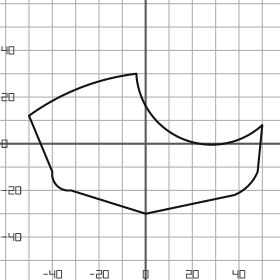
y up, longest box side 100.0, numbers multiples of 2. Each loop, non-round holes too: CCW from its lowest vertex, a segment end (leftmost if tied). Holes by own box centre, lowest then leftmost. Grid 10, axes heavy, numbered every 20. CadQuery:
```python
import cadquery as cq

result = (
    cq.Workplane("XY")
    .moveTo(0.0, -30.0)
    .lineTo(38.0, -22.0)
    .threePointArc((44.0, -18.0), (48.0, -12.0))
    .lineTo(50.0, 8.0)
    .threePointArc((16.0, 2.0), (-4.0, 30.0))
    .threePointArc((-28.0, 24.0), (-50.0, 12.0))
    .lineTo(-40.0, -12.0)
    .threePointArc((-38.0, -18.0), (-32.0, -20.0))
    .close()
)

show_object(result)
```